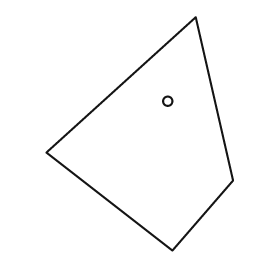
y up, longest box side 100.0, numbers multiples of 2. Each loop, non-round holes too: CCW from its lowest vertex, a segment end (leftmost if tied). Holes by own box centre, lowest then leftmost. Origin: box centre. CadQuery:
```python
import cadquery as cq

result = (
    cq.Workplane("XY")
    .moveTo(14.0, -50.0)
    .lineTo(40.0, -20.0)
    .lineTo(24.0, 50.0)
    .lineTo(-40.0, -8.0)
    .close()
    .moveTo(12.0, 14.0)
    .circle(2.0)
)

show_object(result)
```